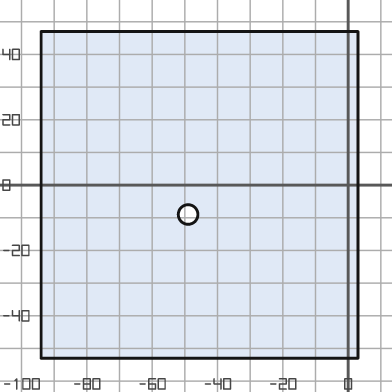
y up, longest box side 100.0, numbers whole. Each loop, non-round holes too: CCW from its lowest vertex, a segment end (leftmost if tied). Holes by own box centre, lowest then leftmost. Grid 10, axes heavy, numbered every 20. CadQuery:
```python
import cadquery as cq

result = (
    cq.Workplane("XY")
    .moveTo(-94.0, -53.0)
    .lineTo(3.0, -53.0)
    .lineTo(3.0, 47.0)
    .lineTo(-94.0, 47.0)
    .close()
    .moveTo(-49.0, -9.0)
    .circle(3.0)
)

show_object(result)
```